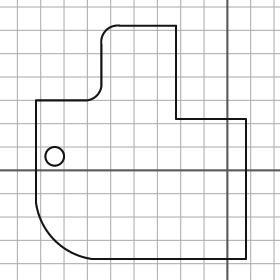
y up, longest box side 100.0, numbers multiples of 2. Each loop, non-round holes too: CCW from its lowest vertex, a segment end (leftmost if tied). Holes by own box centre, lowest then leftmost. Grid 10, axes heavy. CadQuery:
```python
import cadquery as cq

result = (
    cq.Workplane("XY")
    .moveTo(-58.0, -38.0)
    .lineTo(8.0, -38.0)
    .lineTo(8.0, 22.0)
    .lineTo(-22.0, 22.0)
    .lineTo(-22.0, 62.0)
    .lineTo(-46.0, 62.0)
    .threePointArc((-52.0, 60.0), (-54.0, 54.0))
    .lineTo(-54.0, 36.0)
    .threePointArc((-56.0, 32.0), (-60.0, 30.0))
    .lineTo(-82.0, 30.0)
    .lineTo(-82.0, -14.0)
    .threePointArc((-74.0, -30.0), (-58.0, -38.0))
    .close()
    .moveTo(-74.0, 6.0)
    .circle(4.0)
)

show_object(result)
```